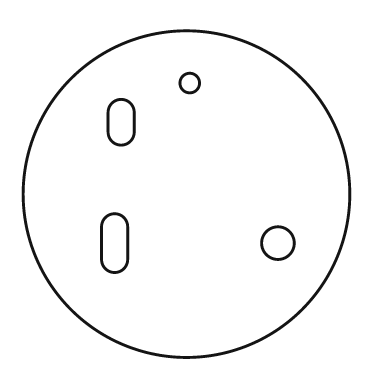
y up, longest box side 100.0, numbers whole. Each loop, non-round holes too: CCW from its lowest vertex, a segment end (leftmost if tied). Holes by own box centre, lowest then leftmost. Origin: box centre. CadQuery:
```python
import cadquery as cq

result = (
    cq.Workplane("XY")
    .moveTo(0.0, 0.0)
    .circle(50.0)
    .moveTo(-26.0, -20.0)
    .threePointArc((-22.0, -24.0), (-18.0, -20.0))
    .lineTo(-18.0, -10.0)
    .threePointArc((-22.0, -6.0), (-26.0, -10.0))
    .close()
    .moveTo(28.0, -15.0)
    .circle(5.0)
    .moveTo(-24.0, 19.0)
    .threePointArc((-20.0, 15.0), (-16.0, 19.0))
    .lineTo(-16.0, 25.0)
    .threePointArc((-20.0, 29.0), (-24.0, 25.0))
    .close()
    .moveTo(1.0, 34.0)
    .circle(3.0)
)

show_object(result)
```